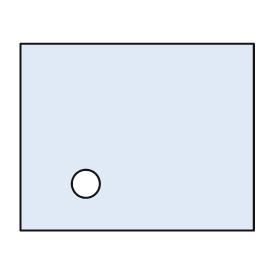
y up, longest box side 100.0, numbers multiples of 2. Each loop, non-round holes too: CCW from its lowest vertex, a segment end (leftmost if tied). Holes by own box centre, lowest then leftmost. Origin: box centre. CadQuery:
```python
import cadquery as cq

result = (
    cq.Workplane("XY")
    .moveTo(-50.0, -40.0)
    .lineTo(50.0, -40.0)
    .lineTo(50.0, 40.0)
    .lineTo(-50.0, 40.0)
    .close()
    .moveTo(-22.0, -20.0)
    .circle(6.0)
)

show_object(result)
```